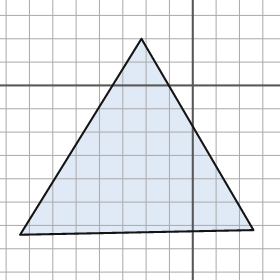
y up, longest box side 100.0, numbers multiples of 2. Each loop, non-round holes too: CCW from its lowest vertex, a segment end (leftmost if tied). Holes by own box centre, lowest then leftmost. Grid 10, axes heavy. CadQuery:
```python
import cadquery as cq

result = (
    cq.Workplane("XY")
    .moveTo(-74.0, -64.0)
    .lineTo(26.0, -62.0)
    .lineTo(-22.0, 20.0)
    .close()
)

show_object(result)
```